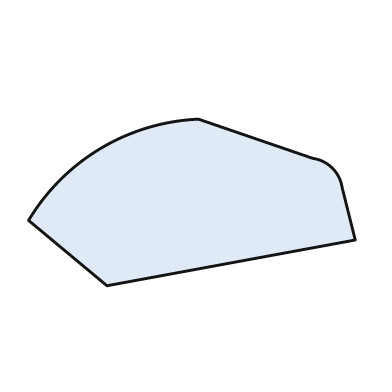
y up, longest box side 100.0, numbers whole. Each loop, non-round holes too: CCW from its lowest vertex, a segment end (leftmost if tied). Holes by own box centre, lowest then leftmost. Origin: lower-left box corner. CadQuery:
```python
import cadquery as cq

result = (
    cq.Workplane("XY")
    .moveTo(24.0, 0.0)
    .lineTo(100.0, 14.0)
    .lineTo(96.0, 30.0)
    .threePointArc((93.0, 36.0), (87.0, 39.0))
    .lineTo(52.0, 51.0)
    .threePointArc((22.0, 42.0), (0.0, 20.0))
    .close()
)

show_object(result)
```